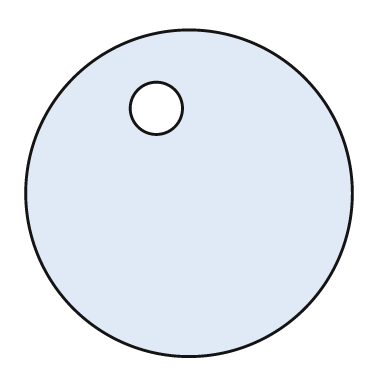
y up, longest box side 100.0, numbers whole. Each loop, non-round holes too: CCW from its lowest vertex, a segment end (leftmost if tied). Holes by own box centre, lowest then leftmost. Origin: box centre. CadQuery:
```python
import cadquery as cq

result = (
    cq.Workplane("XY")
    .moveTo(0.0, 0.0)
    .circle(50.0)
    .moveTo(-10.0, 26.0)
    .circle(8.0)
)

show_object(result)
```